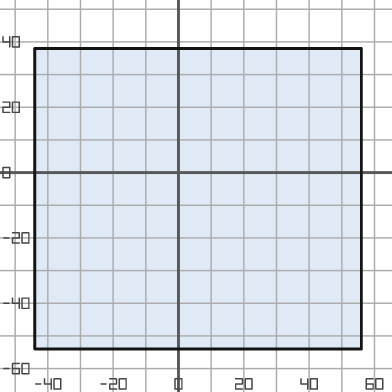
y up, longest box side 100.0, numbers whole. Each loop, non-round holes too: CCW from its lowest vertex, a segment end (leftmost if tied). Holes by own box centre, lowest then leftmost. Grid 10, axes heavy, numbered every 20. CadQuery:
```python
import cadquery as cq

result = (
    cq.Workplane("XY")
    .moveTo(-44.0, -54.0)
    .lineTo(56.0, -54.0)
    .lineTo(56.0, 38.0)
    .lineTo(-44.0, 38.0)
    .close()
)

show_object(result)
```